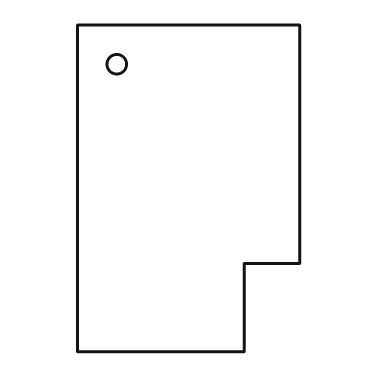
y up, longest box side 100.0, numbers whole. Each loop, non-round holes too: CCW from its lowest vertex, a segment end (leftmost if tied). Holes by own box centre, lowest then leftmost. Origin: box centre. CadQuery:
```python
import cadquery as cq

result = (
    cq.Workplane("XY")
    .moveTo(-34.0, -50.0)
    .lineTo(17.0, -50.0)
    .lineTo(17.0, -23.0)
    .lineTo(34.0, -23.0)
    .lineTo(34.0, 50.0)
    .lineTo(-34.0, 50.0)
    .close()
    .moveTo(-22.0, 38.0)
    .circle(3.0)
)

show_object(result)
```